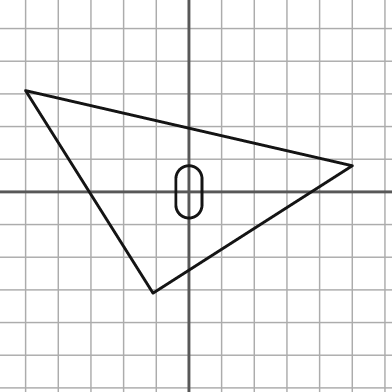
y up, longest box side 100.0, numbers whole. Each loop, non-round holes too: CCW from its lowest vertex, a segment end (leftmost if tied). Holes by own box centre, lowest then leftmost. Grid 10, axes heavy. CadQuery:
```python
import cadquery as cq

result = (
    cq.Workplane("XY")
    .moveTo(-11.0, -31.0)
    .lineTo(50.0, 8.0)
    .lineTo(-50.0, 31.0)
    .close()
    .moveTo(-4.0, -4.0)
    .threePointArc((0.0, -8.0), (4.0, -4.0))
    .lineTo(4.0, 4.0)
    .threePointArc((0.0, 8.0), (-4.0, 4.0))
    .close()
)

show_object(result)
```